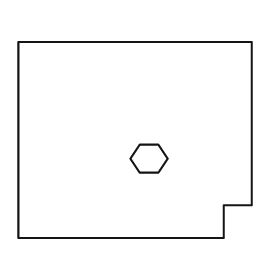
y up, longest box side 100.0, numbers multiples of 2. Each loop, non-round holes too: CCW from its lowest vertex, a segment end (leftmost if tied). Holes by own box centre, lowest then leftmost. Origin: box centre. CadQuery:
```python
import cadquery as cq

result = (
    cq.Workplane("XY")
    .moveTo(-50.0, -42.0)
    .lineTo(38.0, -42.0)
    .lineTo(38.0, -28.0)
    .lineTo(50.0, -28.0)
    .lineTo(50.0, 42.0)
    .lineTo(-50.0, 42.0)
    .close()
    .moveTo(2.0, -14.0)
    .lineTo(10.0, -14.0)
    .lineTo(14.0, -8.0)
    .lineTo(10.0, -2.0)
    .lineTo(2.0, -2.0)
    .lineTo(-2.0, -8.0)
    .close()
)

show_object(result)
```